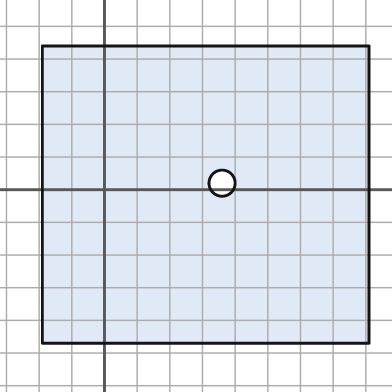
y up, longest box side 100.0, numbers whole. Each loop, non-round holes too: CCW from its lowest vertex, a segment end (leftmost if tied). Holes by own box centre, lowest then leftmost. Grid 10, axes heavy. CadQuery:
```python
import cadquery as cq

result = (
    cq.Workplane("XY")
    .moveTo(-19.0, -47.0)
    .lineTo(81.0, -47.0)
    .lineTo(81.0, 44.0)
    .lineTo(-19.0, 44.0)
    .close()
    .moveTo(36.0, 2.0)
    .circle(4.0)
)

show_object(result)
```